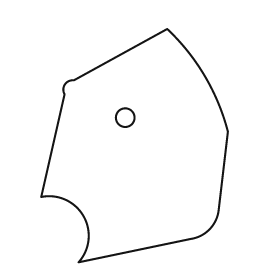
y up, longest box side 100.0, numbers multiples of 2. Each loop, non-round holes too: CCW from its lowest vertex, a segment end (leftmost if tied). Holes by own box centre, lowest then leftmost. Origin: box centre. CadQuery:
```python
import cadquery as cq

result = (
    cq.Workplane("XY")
    .moveTo(-24.0, -50.0)
    .lineTo(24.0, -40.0)
    .threePointArc((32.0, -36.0), (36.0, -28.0))
    .lineTo(40.0, 6.0)
    .threePointArc((30.0, 30.0), (14.0, 50.0))
    .lineTo(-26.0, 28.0)
    .threePointArc((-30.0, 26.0), (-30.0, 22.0))
    .lineTo(-40.0, -22.0)
    .threePointArc((-22.0, -30.0), (-24.0, -50.0))
    .close()
    .moveTo(-4.0, 12.0)
    .circle(4.0)
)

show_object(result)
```